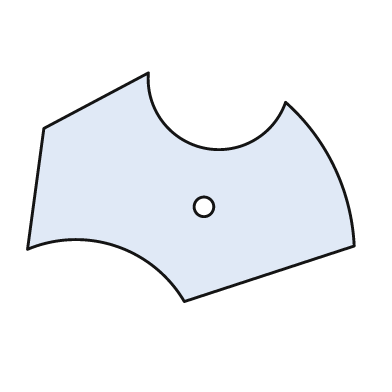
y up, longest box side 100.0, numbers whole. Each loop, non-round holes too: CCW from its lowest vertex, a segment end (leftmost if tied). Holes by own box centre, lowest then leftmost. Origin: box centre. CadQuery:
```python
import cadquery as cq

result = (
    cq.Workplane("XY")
    .moveTo(-2.0, -35.0)
    .lineTo(50.0, -18.0)
    .threePointArc((44.0, 6.0), (29.0, 26.0))
    .threePointArc((4.0, 12.0), (-13.0, 35.0))
    .lineTo(-45.0, 18.0)
    .lineTo(-50.0, -19.0)
    .threePointArc((-23.0, -18.0), (-2.0, -35.0))
    .close()
    .moveTo(4.0, -6.0)
    .circle(3.0)
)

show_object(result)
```